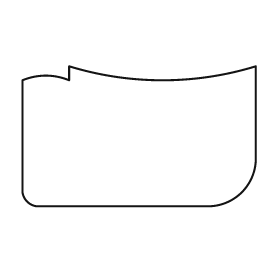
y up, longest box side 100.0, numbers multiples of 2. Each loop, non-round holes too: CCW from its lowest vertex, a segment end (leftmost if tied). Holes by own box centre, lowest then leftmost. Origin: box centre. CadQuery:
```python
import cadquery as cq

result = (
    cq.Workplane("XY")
    .moveTo(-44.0, -30.0)
    .lineTo(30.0, -30.0)
    .threePointArc((44.0, -24.0), (50.0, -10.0))
    .lineTo(50.0, 30.0)
    .threePointArc((10.0, 24.0), (-30.0, 30.0))
    .lineTo(-30.0, 24.0)
    .threePointArc((-40.0, 26.0), (-50.0, 24.0))
    .lineTo(-50.0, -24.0)
    .threePointArc((-48.0, -28.0), (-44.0, -30.0))
    .close()
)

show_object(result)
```